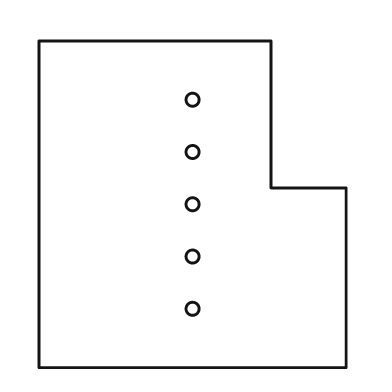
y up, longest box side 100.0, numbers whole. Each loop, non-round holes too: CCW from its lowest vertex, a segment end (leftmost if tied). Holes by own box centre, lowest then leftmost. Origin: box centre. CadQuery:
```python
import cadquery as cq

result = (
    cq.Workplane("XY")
    .moveTo(-47.0, -50.0)
    .lineTo(47.0, -50.0)
    .lineTo(47.0, 5.0)
    .lineTo(24.0, 5.0)
    .lineTo(24.0, 50.0)
    .lineTo(-47.0, 50.0)
    .close()
    .moveTo(0.0, -32.0)
    .circle(2.0)
    .moveTo(0.0, -16.0)
    .circle(2.0)
    .moveTo(0.0, 0.0)
    .circle(2.0)
    .moveTo(0.0, 16.0)
    .circle(2.0)
    .moveTo(0.0, 32.0)
    .circle(2.0)
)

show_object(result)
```